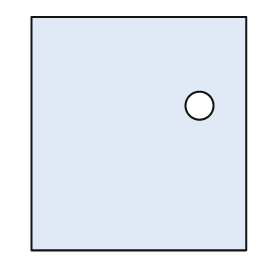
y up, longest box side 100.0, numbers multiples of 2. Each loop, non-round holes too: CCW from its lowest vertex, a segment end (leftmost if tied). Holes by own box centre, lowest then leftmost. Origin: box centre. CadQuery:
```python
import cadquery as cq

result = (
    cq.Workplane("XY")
    .moveTo(-46.0, -50.0)
    .lineTo(46.0, -50.0)
    .lineTo(46.0, 50.0)
    .lineTo(-46.0, 50.0)
    .close()
    .moveTo(26.0, 12.0)
    .circle(6.0)
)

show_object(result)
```